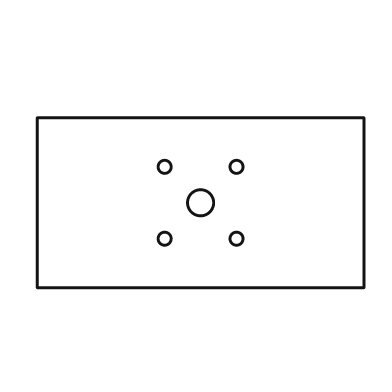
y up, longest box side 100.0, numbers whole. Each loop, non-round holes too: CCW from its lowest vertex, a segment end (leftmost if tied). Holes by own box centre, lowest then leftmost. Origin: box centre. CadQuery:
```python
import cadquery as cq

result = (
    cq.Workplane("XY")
    .moveTo(-50.0, -26.0)
    .lineTo(50.0, -26.0)
    .lineTo(50.0, 26.0)
    .lineTo(-50.0, 26.0)
    .close()
    .moveTo(-11.0, -11.0)
    .circle(2.0)
    .moveTo(11.0, -11.0)
    .circle(2.0)
    .moveTo(0.0, 0.0)
    .circle(4.0)
    .moveTo(-11.0, 11.0)
    .circle(2.0)
    .moveTo(11.0, 11.0)
    .circle(2.0)
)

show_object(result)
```